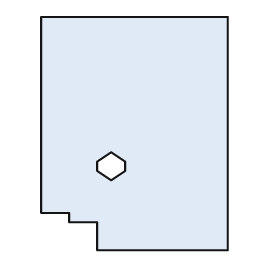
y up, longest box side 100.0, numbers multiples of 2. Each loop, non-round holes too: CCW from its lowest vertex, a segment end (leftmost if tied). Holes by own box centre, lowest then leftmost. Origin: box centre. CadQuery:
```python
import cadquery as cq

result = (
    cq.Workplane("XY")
    .moveTo(-16.0, -50.0)
    .lineTo(40.0, -50.0)
    .lineTo(40.0, 50.0)
    .lineTo(-40.0, 50.0)
    .lineTo(-40.0, -34.0)
    .lineTo(-28.0, -34.0)
    .lineTo(-28.0, -38.0)
    .lineTo(-16.0, -38.0)
    .close()
    .moveTo(-10.0, -20.0)
    .lineTo(-4.0, -16.0)
    .lineTo(-4.0, -12.0)
    .lineTo(-10.0, -8.0)
    .lineTo(-16.0, -12.0)
    .lineTo(-16.0, -16.0)
    .close()
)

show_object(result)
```